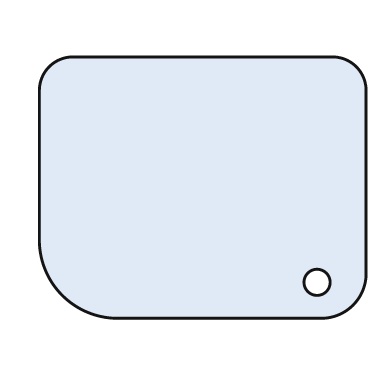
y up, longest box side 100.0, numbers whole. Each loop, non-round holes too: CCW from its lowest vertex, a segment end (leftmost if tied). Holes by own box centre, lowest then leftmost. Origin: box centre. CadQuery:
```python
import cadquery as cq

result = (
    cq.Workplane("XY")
    .moveTo(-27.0, -40.0)
    .lineTo(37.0, -40.0)
    .threePointArc((46.0, -36.0), (50.0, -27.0))
    .lineTo(50.0, 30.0)
    .threePointArc((47.0, 37.0), (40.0, 40.0))
    .lineTo(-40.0, 40.0)
    .threePointArc((-47.0, 37.0), (-50.0, 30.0))
    .lineTo(-50.0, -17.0)
    .threePointArc((-43.0, -33.0), (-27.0, -40.0))
    .close()
    .moveTo(35.0, -29.0)
    .circle(4.0)
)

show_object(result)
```